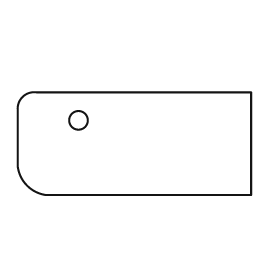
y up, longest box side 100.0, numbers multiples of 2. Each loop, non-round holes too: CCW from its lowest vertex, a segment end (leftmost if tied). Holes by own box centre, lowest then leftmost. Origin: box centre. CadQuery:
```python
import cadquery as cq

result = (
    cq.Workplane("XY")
    .moveTo(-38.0, -22.0)
    .lineTo(50.0, -22.0)
    .lineTo(50.0, 22.0)
    .lineTo(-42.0, 22.0)
    .threePointArc((-48.0, 20.0), (-50.0, 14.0))
    .lineTo(-50.0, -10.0)
    .threePointArc((-46.0, -18.0), (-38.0, -22.0))
    .close()
    .moveTo(-24.0, 10.0)
    .circle(4.0)
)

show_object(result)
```